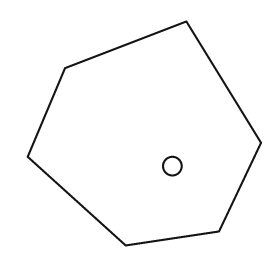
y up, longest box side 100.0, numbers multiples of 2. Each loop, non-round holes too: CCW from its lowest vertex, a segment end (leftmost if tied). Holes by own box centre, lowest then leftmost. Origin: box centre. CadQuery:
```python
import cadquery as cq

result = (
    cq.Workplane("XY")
    .moveTo(-8.0, -48.0)
    .lineTo(32.0, -42.0)
    .lineTo(50.0, -4.0)
    .lineTo(18.0, 48.0)
    .lineTo(-34.0, 28.0)
    .lineTo(-50.0, -10.0)
    .close()
    .moveTo(12.0, -14.0)
    .circle(4.0)
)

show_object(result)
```